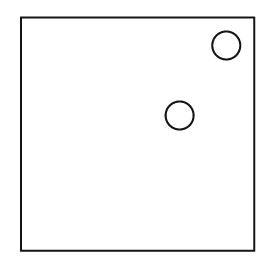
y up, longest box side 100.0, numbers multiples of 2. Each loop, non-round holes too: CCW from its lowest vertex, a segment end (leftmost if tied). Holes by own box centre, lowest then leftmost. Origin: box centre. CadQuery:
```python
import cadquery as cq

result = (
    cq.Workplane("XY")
    .moveTo(-50.0, -50.0)
    .lineTo(50.0, -50.0)
    .lineTo(50.0, 50.0)
    .lineTo(-50.0, 50.0)
    .close()
    .moveTo(18.0, 8.0)
    .circle(6.0)
    .moveTo(38.0, 38.0)
    .circle(6.0)
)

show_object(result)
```